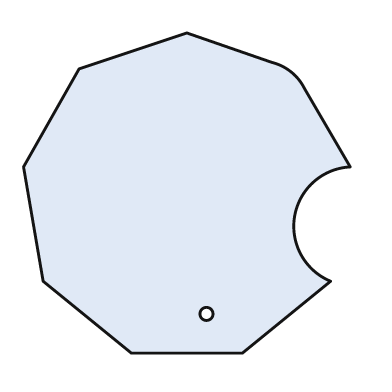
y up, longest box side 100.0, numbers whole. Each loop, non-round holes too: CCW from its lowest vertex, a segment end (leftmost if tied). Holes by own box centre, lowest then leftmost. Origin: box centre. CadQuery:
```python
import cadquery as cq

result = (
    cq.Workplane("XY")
    .moveTo(-17.0, -49.0)
    .lineTo(17.0, -49.0)
    .lineTo(44.0, -27.0)
    .threePointArc((33.0, -7.0), (50.0, 8.0))
    .lineTo(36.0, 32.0)
    .threePointArc((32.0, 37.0), (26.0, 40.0))
    .lineTo(0.0, 49.0)
    .lineTo(-33.0, 38.0)
    .lineTo(-50.0, 8.0)
    .lineTo(-44.0, -27.0)
    .close()
    .moveTo(6.0, -37.0)
    .circle(2.0)
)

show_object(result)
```